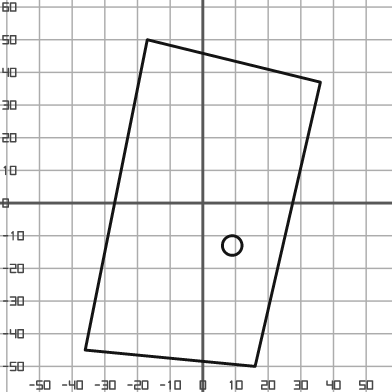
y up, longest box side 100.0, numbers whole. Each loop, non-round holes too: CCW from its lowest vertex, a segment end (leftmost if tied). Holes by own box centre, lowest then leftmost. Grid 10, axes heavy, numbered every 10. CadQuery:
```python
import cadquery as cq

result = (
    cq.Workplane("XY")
    .moveTo(16.0, -50.0)
    .lineTo(36.0, 37.0)
    .lineTo(-17.0, 50.0)
    .lineTo(-36.0, -45.0)
    .close()
    .moveTo(9.0, -13.0)
    .circle(3.0)
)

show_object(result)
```